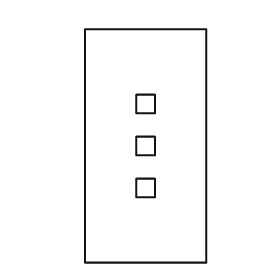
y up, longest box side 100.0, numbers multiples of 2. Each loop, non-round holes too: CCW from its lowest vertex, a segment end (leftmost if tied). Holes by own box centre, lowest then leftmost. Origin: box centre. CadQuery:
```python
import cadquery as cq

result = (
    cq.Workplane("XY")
    .moveTo(-26.0, -50.0)
    .lineTo(26.0, -50.0)
    .lineTo(26.0, 50.0)
    .lineTo(-26.0, 50.0)
    .close()
    .moveTo(-4.0, -22.0)
    .lineTo(4.0, -22.0)
    .lineTo(4.0, -14.0)
    .lineTo(-4.0, -14.0)
    .close()
    .moveTo(-4.0, -4.0)
    .lineTo(4.0, -4.0)
    .lineTo(4.0, 4.0)
    .lineTo(-4.0, 4.0)
    .close()
    .moveTo(-4.0, 14.0)
    .lineTo(4.0, 14.0)
    .lineTo(4.0, 22.0)
    .lineTo(-4.0, 22.0)
    .close()
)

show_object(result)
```